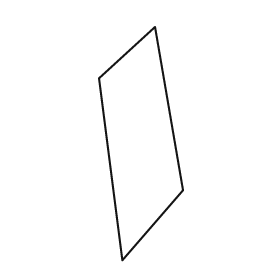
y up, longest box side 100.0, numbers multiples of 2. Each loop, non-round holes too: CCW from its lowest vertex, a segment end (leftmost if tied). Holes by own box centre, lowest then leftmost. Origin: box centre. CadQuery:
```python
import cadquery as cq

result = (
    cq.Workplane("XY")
    .moveTo(-8.0, -50.0)
    .lineTo(18.0, -20.0)
    .lineTo(6.0, 50.0)
    .lineTo(-18.0, 28.0)
    .close()
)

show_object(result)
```